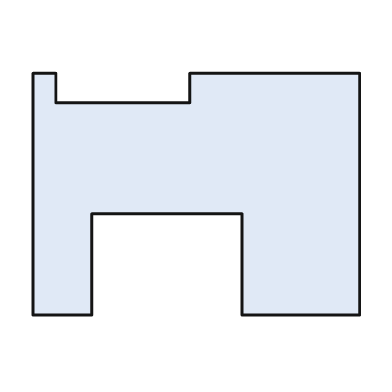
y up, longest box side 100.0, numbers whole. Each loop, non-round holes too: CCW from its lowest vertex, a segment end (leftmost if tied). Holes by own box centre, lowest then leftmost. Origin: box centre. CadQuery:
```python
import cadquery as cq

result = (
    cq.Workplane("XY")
    .moveTo(-50.0, -37.0)
    .lineTo(-32.0, -37.0)
    .lineTo(-32.0, -6.0)
    .lineTo(14.0, -6.0)
    .lineTo(14.0, -37.0)
    .lineTo(50.0, -37.0)
    .lineTo(50.0, 37.0)
    .lineTo(-2.0, 37.0)
    .lineTo(-2.0, 28.0)
    .lineTo(-43.0, 28.0)
    .lineTo(-43.0, 37.0)
    .lineTo(-50.0, 37.0)
    .close()
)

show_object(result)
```